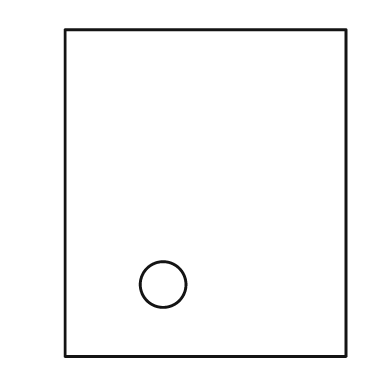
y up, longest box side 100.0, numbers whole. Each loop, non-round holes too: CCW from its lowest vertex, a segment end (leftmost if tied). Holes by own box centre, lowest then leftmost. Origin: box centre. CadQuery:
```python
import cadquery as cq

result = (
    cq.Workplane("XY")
    .moveTo(-43.0, -50.0)
    .lineTo(43.0, -50.0)
    .lineTo(43.0, 50.0)
    .lineTo(-43.0, 50.0)
    .close()
    .moveTo(-13.0, -28.0)
    .circle(7.0)
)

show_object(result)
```